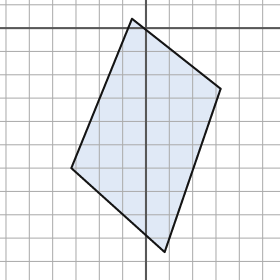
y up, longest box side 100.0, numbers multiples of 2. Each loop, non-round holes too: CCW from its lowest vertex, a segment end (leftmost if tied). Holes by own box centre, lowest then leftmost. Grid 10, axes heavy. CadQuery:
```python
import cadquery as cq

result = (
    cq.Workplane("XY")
    .moveTo(8.0, -96.0)
    .lineTo(32.0, -26.0)
    .lineTo(-6.0, 4.0)
    .lineTo(-32.0, -60.0)
    .close()
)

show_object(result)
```